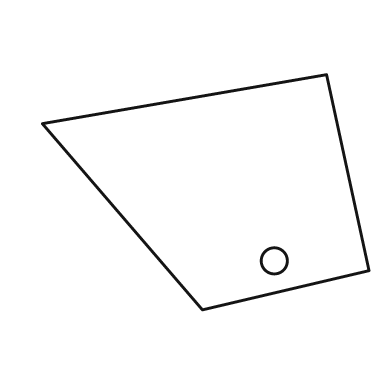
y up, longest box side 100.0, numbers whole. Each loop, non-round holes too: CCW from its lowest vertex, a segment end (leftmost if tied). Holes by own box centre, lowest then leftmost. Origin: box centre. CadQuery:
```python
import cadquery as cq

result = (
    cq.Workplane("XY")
    .moveTo(-1.0, -36.0)
    .lineTo(50.0, -24.0)
    .lineTo(37.0, 36.0)
    .lineTo(-50.0, 21.0)
    .close()
    .moveTo(21.0, -21.0)
    .circle(4.0)
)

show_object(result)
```